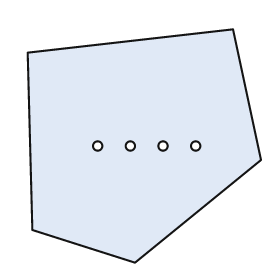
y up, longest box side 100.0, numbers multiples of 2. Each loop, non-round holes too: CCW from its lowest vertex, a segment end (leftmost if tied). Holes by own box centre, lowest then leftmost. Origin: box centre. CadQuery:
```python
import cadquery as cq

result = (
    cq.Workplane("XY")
    .moveTo(-4.0, -50.0)
    .lineTo(50.0, -6.0)
    .lineTo(38.0, 50.0)
    .lineTo(-50.0, 40.0)
    .lineTo(-48.0, -36.0)
    .close()
    .moveTo(-20.0, 0.0)
    .circle(2.0)
    .moveTo(-6.0, 0.0)
    .circle(2.0)
    .moveTo(8.0, 0.0)
    .circle(2.0)
    .moveTo(22.0, 0.0)
    .circle(2.0)
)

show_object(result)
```